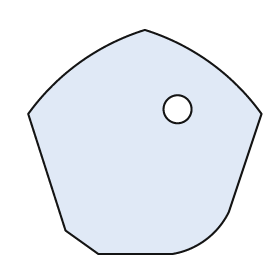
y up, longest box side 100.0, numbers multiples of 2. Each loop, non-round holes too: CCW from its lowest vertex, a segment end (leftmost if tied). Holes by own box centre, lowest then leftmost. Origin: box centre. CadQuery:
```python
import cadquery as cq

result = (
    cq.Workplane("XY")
    .moveTo(-20.0, -48.0)
    .lineTo(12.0, -48.0)
    .threePointArc((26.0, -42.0), (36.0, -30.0))
    .lineTo(50.0, 12.0)
    .threePointArc((28.0, 34.0), (0.0, 48.0))
    .threePointArc((-28.0, 34.0), (-50.0, 12.0))
    .lineTo(-34.0, -38.0)
    .close()
    .moveTo(14.0, 14.0)
    .circle(6.0)
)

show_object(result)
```